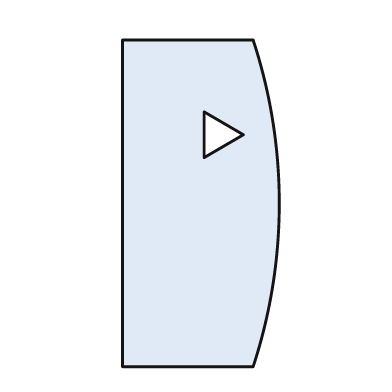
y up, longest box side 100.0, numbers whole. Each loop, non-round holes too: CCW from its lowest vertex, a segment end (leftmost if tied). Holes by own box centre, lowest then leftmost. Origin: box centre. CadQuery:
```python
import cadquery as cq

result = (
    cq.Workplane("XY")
    .moveTo(-24.0, -50.0)
    .lineTo(16.0, -50.0)
    .threePointArc((24.0, 0.0), (16.0, 50.0))
    .lineTo(-24.0, 50.0)
    .close()
    .moveTo(1.0, 14.0)
    .lineTo(13.0, 21.0)
    .lineTo(1.0, 28.0)
    .close()
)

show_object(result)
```